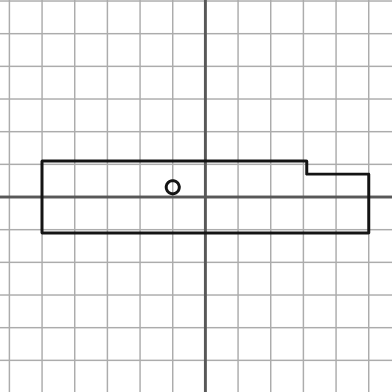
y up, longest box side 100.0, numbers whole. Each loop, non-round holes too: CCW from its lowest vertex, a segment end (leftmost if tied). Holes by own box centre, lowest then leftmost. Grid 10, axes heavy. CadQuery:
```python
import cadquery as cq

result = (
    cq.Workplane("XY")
    .moveTo(-50.0, -11.0)
    .lineTo(50.0, -11.0)
    .lineTo(50.0, 7.0)
    .lineTo(31.0, 7.0)
    .lineTo(31.0, 11.0)
    .lineTo(-50.0, 11.0)
    .close()
    .moveTo(-10.0, 3.0)
    .circle(2.0)
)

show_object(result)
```